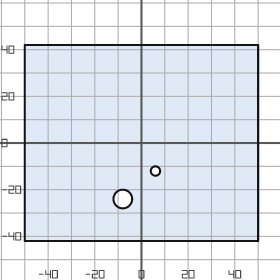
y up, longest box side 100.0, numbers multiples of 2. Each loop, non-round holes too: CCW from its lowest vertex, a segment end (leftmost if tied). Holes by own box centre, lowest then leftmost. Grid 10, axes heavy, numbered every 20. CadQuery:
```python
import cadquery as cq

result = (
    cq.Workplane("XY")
    .moveTo(-50.0, -42.0)
    .lineTo(50.0, -42.0)
    .lineTo(50.0, 42.0)
    .lineTo(-50.0, 42.0)
    .close()
    .moveTo(-8.0, -24.0)
    .circle(4.0)
    .moveTo(6.0, -12.0)
    .circle(2.0)
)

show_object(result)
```